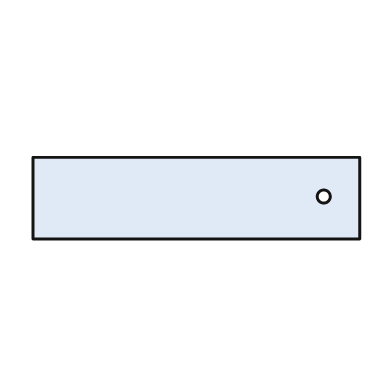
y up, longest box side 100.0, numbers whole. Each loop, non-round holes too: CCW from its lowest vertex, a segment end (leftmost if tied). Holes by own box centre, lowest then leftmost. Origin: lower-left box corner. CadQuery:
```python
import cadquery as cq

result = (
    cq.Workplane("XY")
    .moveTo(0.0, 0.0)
    .lineTo(100.0, 0.0)
    .lineTo(100.0, 25.0)
    .lineTo(0.0, 25.0)
    .close()
    .moveTo(89.0, 13.0)
    .circle(2.0)
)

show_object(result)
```